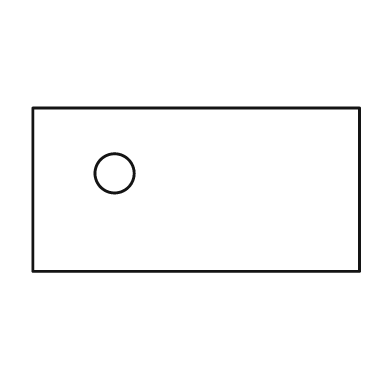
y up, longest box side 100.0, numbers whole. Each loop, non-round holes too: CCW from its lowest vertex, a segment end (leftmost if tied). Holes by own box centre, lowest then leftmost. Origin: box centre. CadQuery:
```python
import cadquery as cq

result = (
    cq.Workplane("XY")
    .moveTo(-50.0, -25.0)
    .lineTo(50.0, -25.0)
    .lineTo(50.0, 25.0)
    .lineTo(-50.0, 25.0)
    .close()
    .moveTo(-25.0, 5.0)
    .circle(6.0)
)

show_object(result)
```